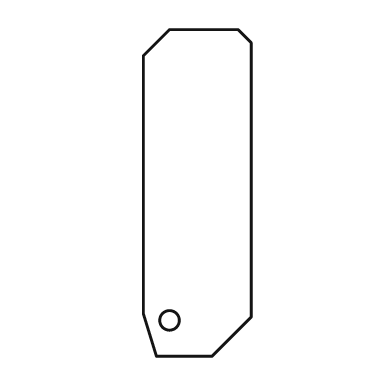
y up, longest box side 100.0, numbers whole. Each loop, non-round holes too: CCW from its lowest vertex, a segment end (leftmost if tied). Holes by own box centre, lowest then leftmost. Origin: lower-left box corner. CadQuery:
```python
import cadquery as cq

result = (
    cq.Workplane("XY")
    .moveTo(4.0, 0.0)
    .lineTo(21.0, 0.0)
    .lineTo(33.0, 12.0)
    .lineTo(33.0, 96.0)
    .lineTo(29.0, 100.0)
    .lineTo(8.0, 100.0)
    .lineTo(0.0, 92.0)
    .lineTo(0.0, 13.0)
    .close()
    .moveTo(8.0, 11.0)
    .circle(3.0)
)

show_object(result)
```